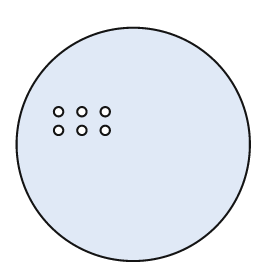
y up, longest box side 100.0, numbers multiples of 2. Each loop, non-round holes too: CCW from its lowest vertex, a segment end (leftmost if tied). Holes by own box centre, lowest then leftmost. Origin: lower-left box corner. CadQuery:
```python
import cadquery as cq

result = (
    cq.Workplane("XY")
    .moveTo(50.0, 50.0)
    .circle(50.0)
    .moveTo(18.0, 56.0)
    .circle(2.0)
    .moveTo(28.0, 56.0)
    .circle(2.0)
    .moveTo(38.0, 56.0)
    .circle(2.0)
    .moveTo(18.0, 64.0)
    .circle(2.0)
    .moveTo(28.0, 64.0)
    .circle(2.0)
    .moveTo(38.0, 64.0)
    .circle(2.0)
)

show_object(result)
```